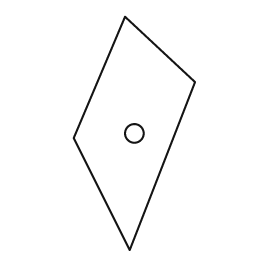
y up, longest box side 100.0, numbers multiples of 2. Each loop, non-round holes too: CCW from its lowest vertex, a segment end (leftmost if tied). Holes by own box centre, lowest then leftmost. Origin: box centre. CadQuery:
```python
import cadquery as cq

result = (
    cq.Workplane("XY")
    .moveTo(-2.0, -50.0)
    .lineTo(26.0, 22.0)
    .lineTo(-4.0, 50.0)
    .lineTo(-26.0, -2.0)
    .close()
    .moveTo(0.0, 0.0)
    .circle(4.0)
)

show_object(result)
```